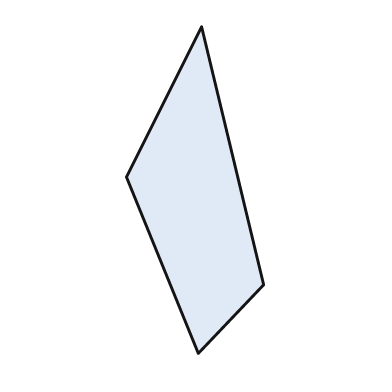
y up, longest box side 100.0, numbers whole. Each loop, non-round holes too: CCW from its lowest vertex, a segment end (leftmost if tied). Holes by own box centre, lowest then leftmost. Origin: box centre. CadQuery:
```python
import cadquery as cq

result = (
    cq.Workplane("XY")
    .moveTo(1.0, -50.0)
    .lineTo(21.0, -29.0)
    .lineTo(2.0, 50.0)
    .lineTo(-21.0, 4.0)
    .close()
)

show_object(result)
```